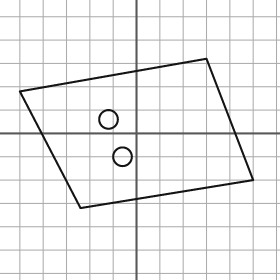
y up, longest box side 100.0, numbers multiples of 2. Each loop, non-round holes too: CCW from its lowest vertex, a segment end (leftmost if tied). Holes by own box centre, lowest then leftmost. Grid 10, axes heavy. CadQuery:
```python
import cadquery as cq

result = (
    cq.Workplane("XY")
    .moveTo(-24.0, -32.0)
    .lineTo(50.0, -20.0)
    .lineTo(30.0, 32.0)
    .lineTo(-50.0, 18.0)
    .close()
    .moveTo(-6.0, -10.0)
    .circle(4.0)
    .moveTo(-12.0, 6.0)
    .circle(4.0)
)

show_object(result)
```